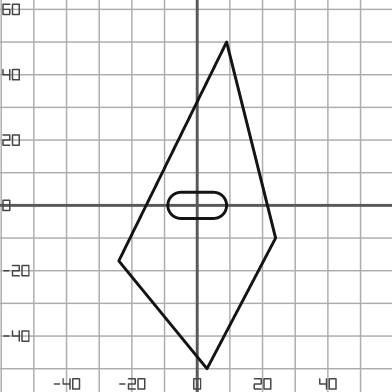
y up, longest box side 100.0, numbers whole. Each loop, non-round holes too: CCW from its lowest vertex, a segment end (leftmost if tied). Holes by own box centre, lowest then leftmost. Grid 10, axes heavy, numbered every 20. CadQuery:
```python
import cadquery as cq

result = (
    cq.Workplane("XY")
    .moveTo(3.0, -50.0)
    .lineTo(24.0, -10.0)
    .lineTo(9.0, 50.0)
    .lineTo(-24.0, -17.0)
    .close()
    .moveTo(-5.0, -4.0)
    .lineTo(5.0, -4.0)
    .threePointArc((9.0, 0.0), (5.0, 4.0))
    .lineTo(-5.0, 4.0)
    .threePointArc((-9.0, 0.0), (-5.0, -4.0))
    .close()
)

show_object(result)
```